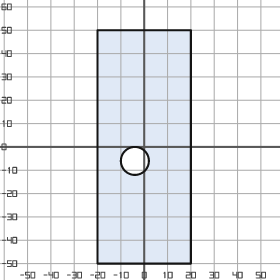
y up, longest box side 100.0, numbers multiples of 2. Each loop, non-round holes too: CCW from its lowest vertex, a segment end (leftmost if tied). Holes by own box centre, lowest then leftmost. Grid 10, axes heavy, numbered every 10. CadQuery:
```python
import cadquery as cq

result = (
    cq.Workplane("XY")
    .moveTo(-20.0, -50.0)
    .lineTo(20.0, -50.0)
    .lineTo(20.0, 50.0)
    .lineTo(-20.0, 50.0)
    .close()
    .moveTo(-4.0, -6.0)
    .circle(6.0)
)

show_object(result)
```